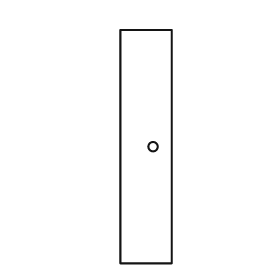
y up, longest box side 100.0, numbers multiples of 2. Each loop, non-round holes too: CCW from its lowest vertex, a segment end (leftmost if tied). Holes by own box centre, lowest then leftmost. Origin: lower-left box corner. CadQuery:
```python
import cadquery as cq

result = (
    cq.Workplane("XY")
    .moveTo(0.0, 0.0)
    .lineTo(22.0, 0.0)
    .lineTo(22.0, 100.0)
    .lineTo(0.0, 100.0)
    .close()
    .moveTo(14.0, 50.0)
    .circle(2.0)
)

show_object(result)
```